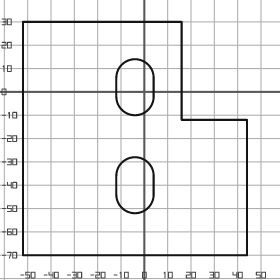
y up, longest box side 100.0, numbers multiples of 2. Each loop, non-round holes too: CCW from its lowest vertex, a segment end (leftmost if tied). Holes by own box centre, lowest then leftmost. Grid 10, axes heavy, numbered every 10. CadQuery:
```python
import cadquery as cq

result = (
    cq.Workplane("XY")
    .moveTo(-52.0, -70.0)
    .lineTo(44.0, -70.0)
    .lineTo(44.0, -12.0)
    .lineTo(16.0, -12.0)
    .lineTo(16.0, 30.0)
    .lineTo(-52.0, 30.0)
    .close()
    .moveTo(-12.0, -44.0)
    .threePointArc((-4.0, -52.0), (4.0, -44.0))
    .lineTo(4.0, -36.0)
    .threePointArc((-4.0, -28.0), (-12.0, -36.0))
    .close()
    .moveTo(-12.0, -2.0)
    .threePointArc((-4.0, -10.0), (4.0, -2.0))
    .lineTo(4.0, 6.0)
    .threePointArc((-4.0, 14.0), (-12.0, 6.0))
    .close()
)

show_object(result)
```